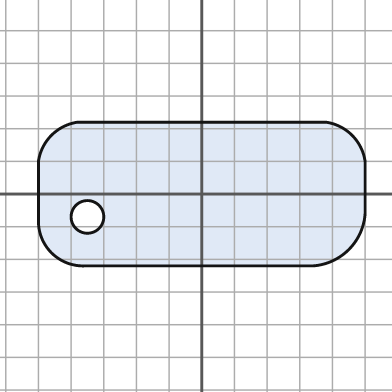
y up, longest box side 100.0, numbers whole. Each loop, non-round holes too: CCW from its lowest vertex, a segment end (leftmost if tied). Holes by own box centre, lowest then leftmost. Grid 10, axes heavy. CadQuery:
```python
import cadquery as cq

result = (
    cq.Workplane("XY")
    .moveTo(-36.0, -22.0)
    .lineTo(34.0, -22.0)
    .threePointArc((45.0, -17.0), (50.0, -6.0))
    .lineTo(50.0, 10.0)
    .threePointArc((46.0, 18.0), (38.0, 22.0))
    .lineTo(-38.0, 22.0)
    .threePointArc((-46.0, 18.0), (-50.0, 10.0))
    .lineTo(-50.0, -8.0)
    .threePointArc((-46.0, -18.0), (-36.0, -22.0))
    .close()
    .moveTo(-35.0, -7.0)
    .circle(5.0)
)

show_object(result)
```